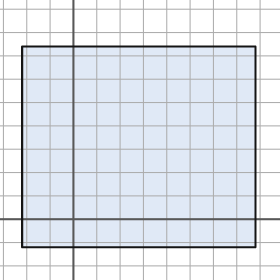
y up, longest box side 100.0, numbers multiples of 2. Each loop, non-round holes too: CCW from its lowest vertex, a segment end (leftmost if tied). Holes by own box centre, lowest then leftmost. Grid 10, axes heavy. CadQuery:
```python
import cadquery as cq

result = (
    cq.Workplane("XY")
    .moveTo(-22.0, -12.0)
    .lineTo(78.0, -12.0)
    .lineTo(78.0, 74.0)
    .lineTo(-22.0, 74.0)
    .close()
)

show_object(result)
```